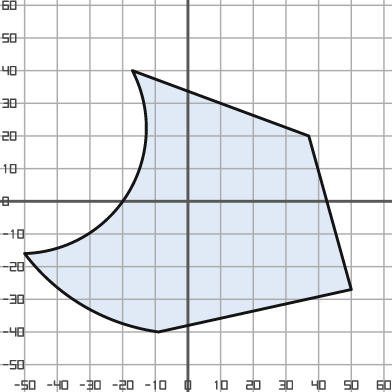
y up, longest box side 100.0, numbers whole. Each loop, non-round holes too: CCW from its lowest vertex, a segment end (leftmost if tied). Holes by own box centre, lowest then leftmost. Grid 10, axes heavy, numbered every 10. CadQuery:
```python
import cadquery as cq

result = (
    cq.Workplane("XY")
    .moveTo(-9.0, -40.0)
    .lineTo(50.0, -27.0)
    .lineTo(37.0, 20.0)
    .lineTo(-17.0, 40.0)
    .threePointArc((-18.0, 3.0), (-50.0, -16.0))
    .threePointArc((-32.0, -32.0), (-9.0, -40.0))
    .close()
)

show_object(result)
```